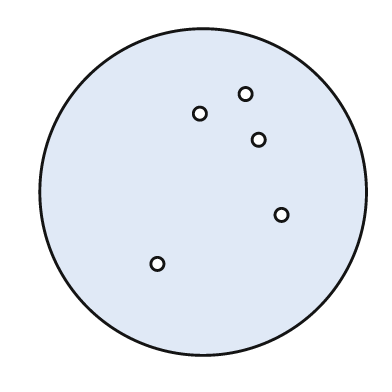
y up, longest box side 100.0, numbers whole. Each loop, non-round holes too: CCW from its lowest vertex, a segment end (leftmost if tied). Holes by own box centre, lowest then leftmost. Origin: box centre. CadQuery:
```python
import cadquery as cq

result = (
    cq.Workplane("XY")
    .moveTo(0.0, 0.0)
    .circle(50.0)
    .moveTo(-14.0, -22.0)
    .circle(2.0)
    .moveTo(24.0, -7.0)
    .circle(2.0)
    .moveTo(17.0, 16.0)
    .circle(2.0)
    .moveTo(-1.0, 24.0)
    .circle(2.0)
    .moveTo(13.0, 30.0)
    .circle(2.0)
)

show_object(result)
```